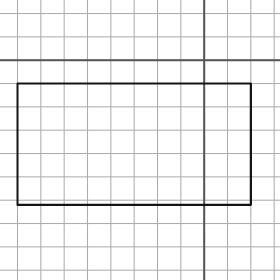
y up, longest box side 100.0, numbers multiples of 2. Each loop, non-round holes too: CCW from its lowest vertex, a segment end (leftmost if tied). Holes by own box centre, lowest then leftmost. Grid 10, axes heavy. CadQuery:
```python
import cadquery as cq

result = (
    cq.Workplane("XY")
    .moveTo(-80.0, -62.0)
    .lineTo(20.0, -62.0)
    .lineTo(20.0, -10.0)
    .lineTo(-80.0, -10.0)
    .close()
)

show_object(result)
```